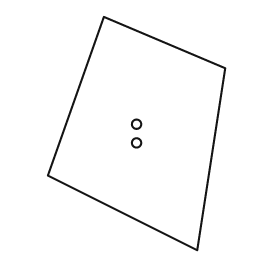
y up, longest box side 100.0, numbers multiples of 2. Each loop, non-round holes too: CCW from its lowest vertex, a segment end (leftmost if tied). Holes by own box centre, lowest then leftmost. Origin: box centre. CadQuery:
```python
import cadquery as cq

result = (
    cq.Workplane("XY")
    .moveTo(26.0, -50.0)
    .lineTo(38.0, 28.0)
    .lineTo(-14.0, 50.0)
    .lineTo(-38.0, -18.0)
    .close()
    .moveTo(0.0, -4.0)
    .circle(2.0)
    .moveTo(0.0, 4.0)
    .circle(2.0)
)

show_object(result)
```